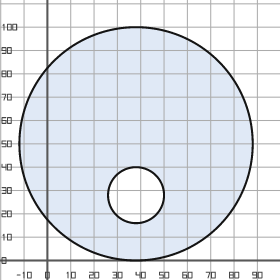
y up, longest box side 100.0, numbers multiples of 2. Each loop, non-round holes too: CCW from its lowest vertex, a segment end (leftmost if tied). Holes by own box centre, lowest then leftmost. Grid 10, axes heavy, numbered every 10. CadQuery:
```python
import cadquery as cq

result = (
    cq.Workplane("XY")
    .moveTo(38.0, 50.0)
    .circle(50.0)
    .moveTo(38.0, 28.0)
    .circle(12.0)
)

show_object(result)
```